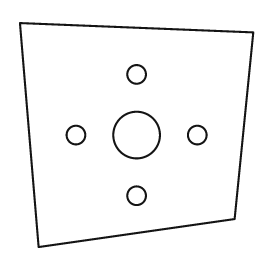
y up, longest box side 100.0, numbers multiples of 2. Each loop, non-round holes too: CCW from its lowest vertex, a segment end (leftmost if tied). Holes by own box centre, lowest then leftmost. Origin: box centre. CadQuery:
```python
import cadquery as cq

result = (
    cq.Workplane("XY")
    .moveTo(-42.0, -48.0)
    .lineTo(42.0, -36.0)
    .lineTo(50.0, 44.0)
    .lineTo(-50.0, 48.0)
    .close()
    .moveTo(0.0, -26.0)
    .circle(4.0)
    .moveTo(-26.0, 0.0)
    .circle(4.0)
    .moveTo(0.0, 0.0)
    .circle(10.0)
    .moveTo(26.0, 0.0)
    .circle(4.0)
    .moveTo(0.0, 26.0)
    .circle(4.0)
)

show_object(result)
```